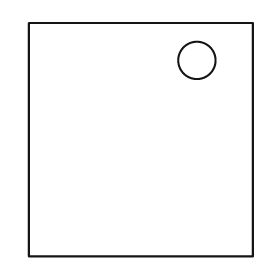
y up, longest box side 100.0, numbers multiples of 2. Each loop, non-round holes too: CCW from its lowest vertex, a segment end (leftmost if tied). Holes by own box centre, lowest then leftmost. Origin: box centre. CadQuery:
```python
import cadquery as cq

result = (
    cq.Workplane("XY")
    .moveTo(-48.0, -50.0)
    .lineTo(48.0, -50.0)
    .lineTo(48.0, 50.0)
    .lineTo(-48.0, 50.0)
    .close()
    .moveTo(24.0, 34.0)
    .circle(8.0)
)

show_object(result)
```